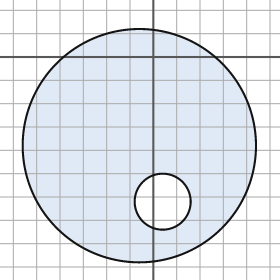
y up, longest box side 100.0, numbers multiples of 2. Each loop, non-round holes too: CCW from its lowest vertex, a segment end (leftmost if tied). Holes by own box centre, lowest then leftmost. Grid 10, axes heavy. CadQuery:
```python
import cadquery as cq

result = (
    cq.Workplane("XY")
    .moveTo(-6.0, -38.0)
    .circle(50.0)
    .moveTo(4.0, -62.0)
    .circle(12.0)
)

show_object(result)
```